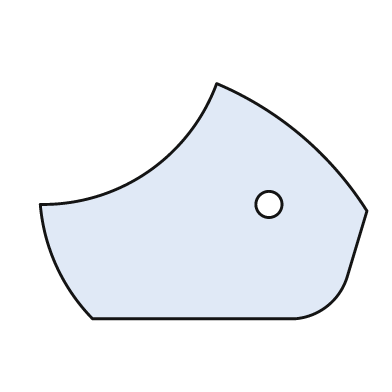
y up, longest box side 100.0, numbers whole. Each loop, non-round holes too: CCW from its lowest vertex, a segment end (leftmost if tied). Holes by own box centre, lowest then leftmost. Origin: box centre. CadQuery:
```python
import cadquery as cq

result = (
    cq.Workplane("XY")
    .moveTo(-34.0, -36.0)
    .lineTo(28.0, -36.0)
    .threePointArc((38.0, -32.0), (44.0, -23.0))
    .lineTo(50.0, -3.0)
    .threePointArc((30.0, 20.0), (4.0, 36.0))
    .threePointArc((-17.0, 9.0), (-50.0, -1.0))
    .threePointArc((-45.0, -20.0), (-34.0, -36.0))
    .close()
    .moveTo(20.0, -1.0)
    .circle(4.0)
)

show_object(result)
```